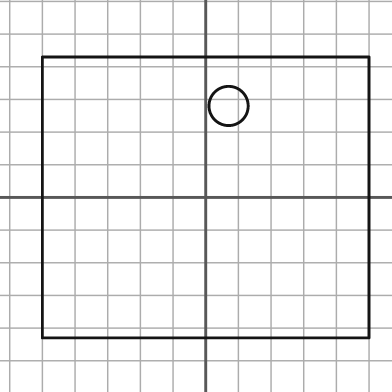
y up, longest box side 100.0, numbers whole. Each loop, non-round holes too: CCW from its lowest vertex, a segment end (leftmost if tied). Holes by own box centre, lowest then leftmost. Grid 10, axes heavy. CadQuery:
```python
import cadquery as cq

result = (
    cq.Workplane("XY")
    .moveTo(-50.0, -43.0)
    .lineTo(50.0, -43.0)
    .lineTo(50.0, 43.0)
    .lineTo(-50.0, 43.0)
    .close()
    .moveTo(7.0, 28.0)
    .circle(6.0)
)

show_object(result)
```